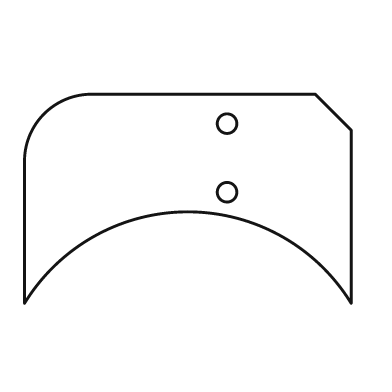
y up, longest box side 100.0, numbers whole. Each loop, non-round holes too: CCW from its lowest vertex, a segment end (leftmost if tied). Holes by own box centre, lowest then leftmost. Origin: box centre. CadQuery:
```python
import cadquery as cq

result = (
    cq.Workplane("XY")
    .moveTo(-50.0, -32.0)
    .threePointArc((0.0, -4.0), (50.0, -32.0))
    .lineTo(50.0, 21.0)
    .lineTo(39.0, 32.0)
    .lineTo(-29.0, 32.0)
    .threePointArc((-44.0, 26.0), (-50.0, 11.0))
    .close()
    .moveTo(12.0, 2.0)
    .circle(3.0)
    .moveTo(12.0, 23.0)
    .circle(3.0)
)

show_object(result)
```